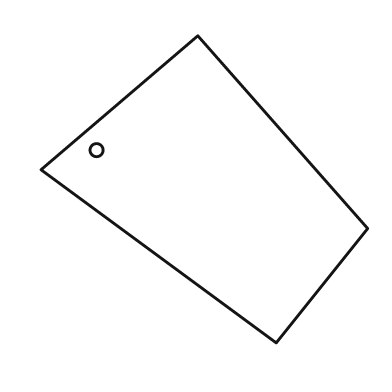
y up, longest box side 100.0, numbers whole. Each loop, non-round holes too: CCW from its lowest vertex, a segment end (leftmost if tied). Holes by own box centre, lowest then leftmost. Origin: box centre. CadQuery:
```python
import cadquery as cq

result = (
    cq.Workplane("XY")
    .moveTo(22.0, -47.0)
    .lineTo(50.0, -12.0)
    .lineTo(-2.0, 47.0)
    .lineTo(-50.0, 6.0)
    .close()
    .moveTo(-33.0, 12.0)
    .circle(2.0)
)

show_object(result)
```